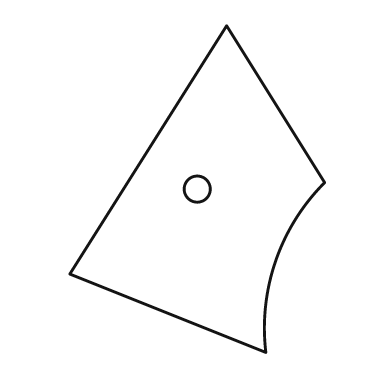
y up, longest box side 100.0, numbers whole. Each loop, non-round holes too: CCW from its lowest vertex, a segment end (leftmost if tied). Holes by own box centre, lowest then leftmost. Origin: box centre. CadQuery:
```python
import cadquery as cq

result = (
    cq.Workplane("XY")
    .moveTo(21.0, -50.0)
    .threePointArc((24.0, -22.0), (39.0, 2.0))
    .lineTo(9.0, 50.0)
    .lineTo(-39.0, -26.0)
    .close()
    .moveTo(0.0, 0.0)
    .circle(4.0)
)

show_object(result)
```